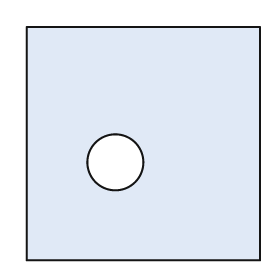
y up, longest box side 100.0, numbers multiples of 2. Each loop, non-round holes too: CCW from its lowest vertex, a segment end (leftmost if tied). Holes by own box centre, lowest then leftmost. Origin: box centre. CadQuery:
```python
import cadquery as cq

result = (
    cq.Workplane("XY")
    .moveTo(-50.0, -50.0)
    .lineTo(50.0, -50.0)
    .lineTo(50.0, 50.0)
    .lineTo(-50.0, 50.0)
    .close()
    .moveTo(-12.0, -8.0)
    .circle(12.0)
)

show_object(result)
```